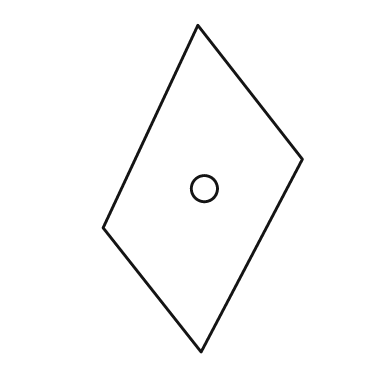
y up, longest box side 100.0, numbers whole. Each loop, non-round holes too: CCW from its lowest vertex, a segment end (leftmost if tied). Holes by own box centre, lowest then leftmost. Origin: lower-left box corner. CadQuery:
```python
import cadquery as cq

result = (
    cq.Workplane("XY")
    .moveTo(30.0, 0.0)
    .lineTo(61.0, 59.0)
    .lineTo(29.0, 100.0)
    .lineTo(0.0, 38.0)
    .close()
    .moveTo(31.0, 50.0)
    .circle(4.0)
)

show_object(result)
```